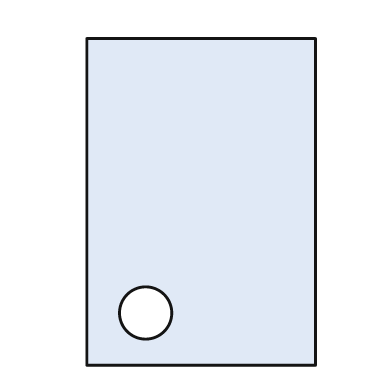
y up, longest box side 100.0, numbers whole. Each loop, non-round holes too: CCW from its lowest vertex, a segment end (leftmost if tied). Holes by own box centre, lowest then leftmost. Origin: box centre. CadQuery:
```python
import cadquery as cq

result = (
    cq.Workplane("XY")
    .moveTo(-35.0, -50.0)
    .lineTo(35.0, -50.0)
    .lineTo(35.0, 50.0)
    .lineTo(-35.0, 50.0)
    .close()
    .moveTo(-17.0, -34.0)
    .circle(8.0)
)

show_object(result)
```